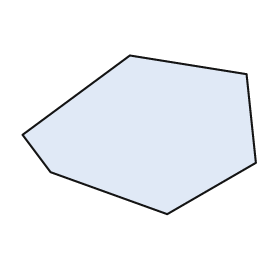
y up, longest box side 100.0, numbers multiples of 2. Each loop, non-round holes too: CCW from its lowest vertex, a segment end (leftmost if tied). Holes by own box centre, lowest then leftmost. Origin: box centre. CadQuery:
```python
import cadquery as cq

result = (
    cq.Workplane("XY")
    .moveTo(12.0, -34.0)
    .lineTo(50.0, -12.0)
    .lineTo(46.0, 26.0)
    .lineTo(-4.0, 34.0)
    .lineTo(-50.0, 0.0)
    .lineTo(-38.0, -16.0)
    .close()
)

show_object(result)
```